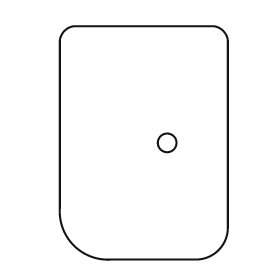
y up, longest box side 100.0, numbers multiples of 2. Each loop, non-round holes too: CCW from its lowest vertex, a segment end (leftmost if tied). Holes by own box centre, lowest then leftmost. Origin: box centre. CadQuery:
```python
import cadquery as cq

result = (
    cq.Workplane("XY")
    .moveTo(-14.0, -50.0)
    .lineTo(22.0, -50.0)
    .threePointArc((32.0, -46.0), (36.0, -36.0))
    .lineTo(36.0, 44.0)
    .threePointArc((34.0, 48.0), (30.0, 50.0))
    .lineTo(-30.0, 50.0)
    .threePointArc((-34.0, 48.0), (-36.0, 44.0))
    .lineTo(-36.0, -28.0)
    .threePointArc((-30.0, -44.0), (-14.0, -50.0))
    .close()
    .moveTo(10.0, 0.0)
    .circle(4.0)
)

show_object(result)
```